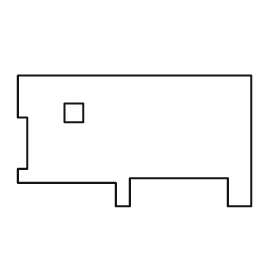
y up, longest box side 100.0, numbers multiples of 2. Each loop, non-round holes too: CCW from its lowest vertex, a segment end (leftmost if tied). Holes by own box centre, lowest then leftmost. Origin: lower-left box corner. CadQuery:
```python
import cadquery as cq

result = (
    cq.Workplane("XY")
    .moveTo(42.0, 0.0)
    .lineTo(48.0, 0.0)
    .lineTo(48.0, 12.0)
    .lineTo(90.0, 12.0)
    .lineTo(90.0, 0.0)
    .lineTo(100.0, 0.0)
    .lineTo(100.0, 56.0)
    .lineTo(0.0, 56.0)
    .lineTo(0.0, 38.0)
    .lineTo(4.0, 38.0)
    .lineTo(4.0, 16.0)
    .lineTo(0.0, 16.0)
    .lineTo(0.0, 10.0)
    .lineTo(42.0, 10.0)
    .close()
    .moveTo(20.0, 36.0)
    .lineTo(28.0, 36.0)
    .lineTo(28.0, 44.0)
    .lineTo(20.0, 44.0)
    .close()
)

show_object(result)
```